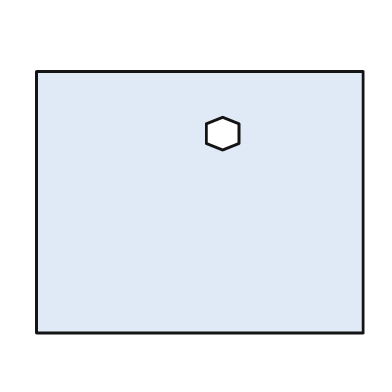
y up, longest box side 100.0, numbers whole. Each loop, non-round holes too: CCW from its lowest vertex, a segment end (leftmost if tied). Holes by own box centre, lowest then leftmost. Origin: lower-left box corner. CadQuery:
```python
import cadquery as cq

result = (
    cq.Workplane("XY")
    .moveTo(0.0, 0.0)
    .lineTo(100.0, 0.0)
    .lineTo(100.0, 80.0)
    .lineTo(0.0, 80.0)
    .close()
    .moveTo(57.0, 56.0)
    .lineTo(62.0, 58.0)
    .lineTo(62.0, 64.0)
    .lineTo(57.0, 66.0)
    .lineTo(52.0, 64.0)
    .lineTo(52.0, 58.0)
    .close()
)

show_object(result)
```